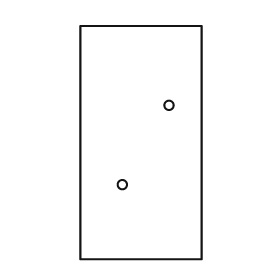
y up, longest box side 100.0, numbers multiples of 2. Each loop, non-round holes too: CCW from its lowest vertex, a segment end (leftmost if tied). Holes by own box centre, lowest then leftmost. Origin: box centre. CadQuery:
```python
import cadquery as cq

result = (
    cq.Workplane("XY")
    .moveTo(-26.0, -50.0)
    .lineTo(26.0, -50.0)
    .lineTo(26.0, 50.0)
    .lineTo(-26.0, 50.0)
    .close()
    .moveTo(-8.0, -18.0)
    .circle(2.0)
    .moveTo(12.0, 16.0)
    .circle(2.0)
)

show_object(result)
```